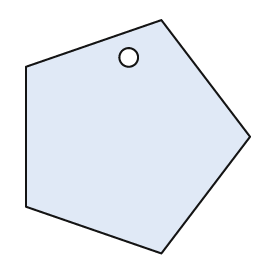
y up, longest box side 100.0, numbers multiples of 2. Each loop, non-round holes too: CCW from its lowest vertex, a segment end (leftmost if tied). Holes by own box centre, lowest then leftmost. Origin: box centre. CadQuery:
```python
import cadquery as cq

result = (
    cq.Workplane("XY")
    .moveTo(10.0, -50.0)
    .lineTo(48.0, 0.0)
    .lineTo(10.0, 50.0)
    .lineTo(-48.0, 30.0)
    .lineTo(-48.0, -30.0)
    .close()
    .moveTo(-4.0, 34.0)
    .circle(4.0)
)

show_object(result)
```